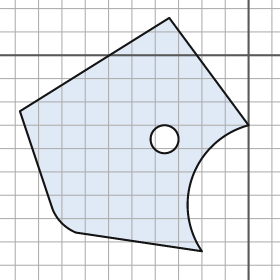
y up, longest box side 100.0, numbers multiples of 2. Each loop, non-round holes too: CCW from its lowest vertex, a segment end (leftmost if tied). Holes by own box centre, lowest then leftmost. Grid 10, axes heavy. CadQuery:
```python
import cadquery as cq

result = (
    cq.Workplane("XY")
    .moveTo(-20.0, -84.0)
    .threePointArc((-24.0, -52.0), (0.0, -30.0))
    .lineTo(-34.0, 16.0)
    .lineTo(-98.0, -24.0)
    .lineTo(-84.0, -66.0)
    .threePointArc((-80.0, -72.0), (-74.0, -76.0))
    .close()
    .moveTo(-36.0, -36.0)
    .circle(6.0)
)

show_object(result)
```